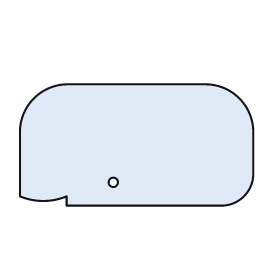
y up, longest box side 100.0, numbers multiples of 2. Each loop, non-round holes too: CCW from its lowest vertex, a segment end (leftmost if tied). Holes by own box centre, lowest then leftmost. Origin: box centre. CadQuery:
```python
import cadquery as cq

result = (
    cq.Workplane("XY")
    .moveTo(-30.0, -26.0)
    .lineTo(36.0, -26.0)
    .threePointArc((46.0, -22.0), (50.0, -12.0))
    .lineTo(50.0, 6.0)
    .threePointArc((44.0, 20.0), (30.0, 26.0))
    .lineTo(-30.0, 26.0)
    .threePointArc((-44.0, 20.0), (-50.0, 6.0))
    .lineTo(-50.0, -22.0)
    .threePointArc((-40.0, -24.0), (-30.0, -22.0))
    .close()
    .moveTo(-10.0, -16.0)
    .circle(2.0)
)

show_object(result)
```